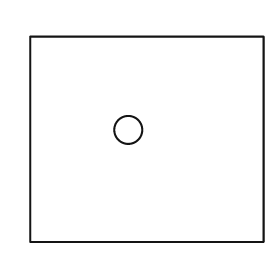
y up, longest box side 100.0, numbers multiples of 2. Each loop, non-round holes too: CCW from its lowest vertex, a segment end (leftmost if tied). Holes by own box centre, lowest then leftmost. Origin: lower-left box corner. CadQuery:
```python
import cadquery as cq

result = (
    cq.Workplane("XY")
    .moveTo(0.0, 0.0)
    .lineTo(100.0, 0.0)
    .lineTo(100.0, 88.0)
    .lineTo(0.0, 88.0)
    .close()
    .moveTo(42.0, 48.0)
    .circle(6.0)
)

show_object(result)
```